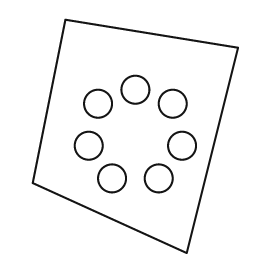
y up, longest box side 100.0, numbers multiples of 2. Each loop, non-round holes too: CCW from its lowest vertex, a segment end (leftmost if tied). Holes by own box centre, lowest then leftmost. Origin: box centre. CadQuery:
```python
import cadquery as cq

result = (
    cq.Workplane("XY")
    .moveTo(22.0, -50.0)
    .lineTo(44.0, 38.0)
    .lineTo(-30.0, 50.0)
    .lineTo(-44.0, -20.0)
    .close()
    .moveTo(-10.0, -18.0)
    .circle(6.0)
    .moveTo(10.0, -18.0)
    .circle(6.0)
    .moveTo(-20.0, -4.0)
    .circle(6.0)
    .moveTo(20.0, -4.0)
    .circle(6.0)
    .moveTo(-16.0, 14.0)
    .circle(6.0)
    .moveTo(16.0, 14.0)
    .circle(6.0)
    .moveTo(0.0, 20.0)
    .circle(6.0)
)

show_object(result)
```